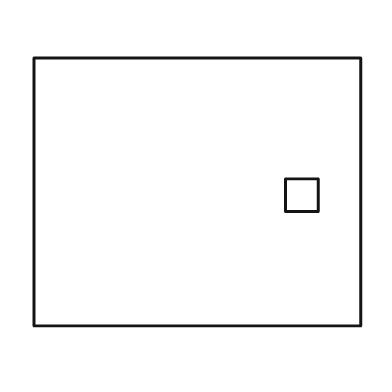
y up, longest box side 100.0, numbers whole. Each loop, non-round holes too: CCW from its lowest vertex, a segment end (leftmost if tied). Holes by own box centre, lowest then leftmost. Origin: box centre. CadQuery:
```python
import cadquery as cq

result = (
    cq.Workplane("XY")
    .moveTo(-50.0, -41.0)
    .lineTo(50.0, -41.0)
    .lineTo(50.0, 41.0)
    .lineTo(-50.0, 41.0)
    .close()
    .moveTo(27.0, -6.0)
    .lineTo(37.0, -6.0)
    .lineTo(37.0, 4.0)
    .lineTo(27.0, 4.0)
    .close()
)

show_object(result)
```